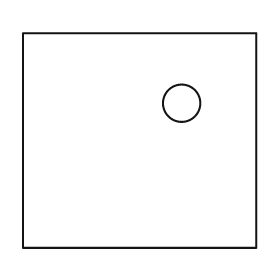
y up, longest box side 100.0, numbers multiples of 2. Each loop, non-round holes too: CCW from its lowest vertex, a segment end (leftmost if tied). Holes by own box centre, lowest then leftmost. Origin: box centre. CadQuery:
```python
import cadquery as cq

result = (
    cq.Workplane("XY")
    .moveTo(-50.0, -46.0)
    .lineTo(50.0, -46.0)
    .lineTo(50.0, 46.0)
    .lineTo(-50.0, 46.0)
    .close()
    .moveTo(18.0, 16.0)
    .circle(8.0)
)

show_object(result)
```